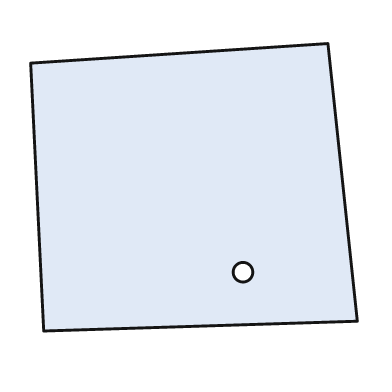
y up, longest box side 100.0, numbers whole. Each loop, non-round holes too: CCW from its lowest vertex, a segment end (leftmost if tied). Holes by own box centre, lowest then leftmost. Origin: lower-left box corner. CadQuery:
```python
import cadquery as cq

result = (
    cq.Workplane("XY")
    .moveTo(4.0, 0.0)
    .lineTo(100.0, 3.0)
    .lineTo(91.0, 88.0)
    .lineTo(0.0, 82.0)
    .close()
    .moveTo(65.0, 18.0)
    .circle(3.0)
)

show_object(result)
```